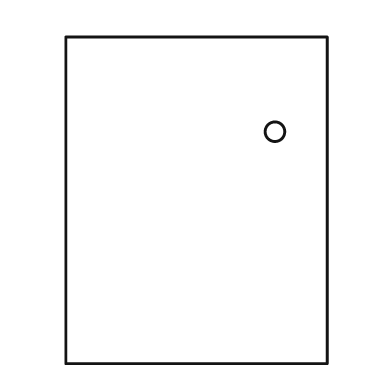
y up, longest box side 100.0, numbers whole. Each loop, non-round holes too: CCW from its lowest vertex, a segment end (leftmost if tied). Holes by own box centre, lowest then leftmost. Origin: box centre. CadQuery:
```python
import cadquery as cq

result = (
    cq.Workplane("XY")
    .moveTo(-40.0, -50.0)
    .lineTo(40.0, -50.0)
    .lineTo(40.0, 50.0)
    .lineTo(-40.0, 50.0)
    .close()
    .moveTo(24.0, 21.0)
    .circle(3.0)
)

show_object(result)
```